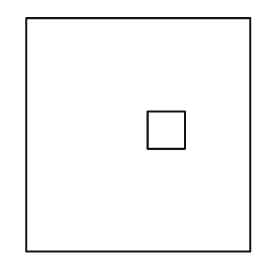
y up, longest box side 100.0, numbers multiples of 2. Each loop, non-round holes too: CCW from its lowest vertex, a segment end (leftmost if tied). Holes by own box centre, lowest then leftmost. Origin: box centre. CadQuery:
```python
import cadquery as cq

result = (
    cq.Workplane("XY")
    .moveTo(-48.0, -50.0)
    .lineTo(48.0, -50.0)
    .lineTo(48.0, 50.0)
    .lineTo(-48.0, 50.0)
    .close()
    .moveTo(4.0, -6.0)
    .lineTo(20.0, -6.0)
    .lineTo(20.0, 10.0)
    .lineTo(4.0, 10.0)
    .close()
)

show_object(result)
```